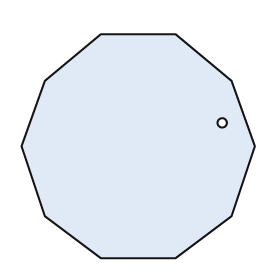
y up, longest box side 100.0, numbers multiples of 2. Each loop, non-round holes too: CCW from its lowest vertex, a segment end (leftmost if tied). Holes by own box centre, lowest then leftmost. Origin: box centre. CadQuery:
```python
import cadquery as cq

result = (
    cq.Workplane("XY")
    .moveTo(-16.0, -48.0)
    .lineTo(16.0, -48.0)
    .lineTo(40.0, -30.0)
    .lineTo(50.0, 0.0)
    .lineTo(40.0, 28.0)
    .lineTo(16.0, 48.0)
    .lineTo(-16.0, 48.0)
    .lineTo(-40.0, 28.0)
    .lineTo(-50.0, 0.0)
    .lineTo(-40.0, -30.0)
    .close()
    .moveTo(36.0, 10.0)
    .circle(2.0)
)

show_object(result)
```